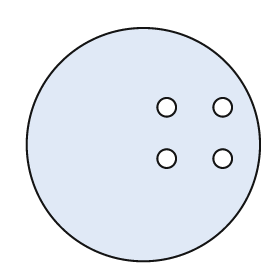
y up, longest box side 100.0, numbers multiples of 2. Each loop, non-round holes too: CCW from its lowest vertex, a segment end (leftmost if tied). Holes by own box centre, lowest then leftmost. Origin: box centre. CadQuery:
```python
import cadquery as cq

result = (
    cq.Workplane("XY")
    .moveTo(0.0, 0.0)
    .circle(50.0)
    .moveTo(10.0, -6.0)
    .circle(4.0)
    .moveTo(34.0, -6.0)
    .circle(4.0)
    .moveTo(10.0, 16.0)
    .circle(4.0)
    .moveTo(34.0, 16.0)
    .circle(4.0)
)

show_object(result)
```